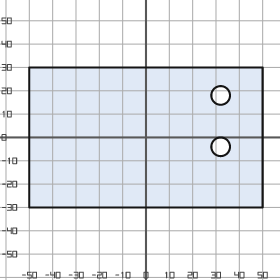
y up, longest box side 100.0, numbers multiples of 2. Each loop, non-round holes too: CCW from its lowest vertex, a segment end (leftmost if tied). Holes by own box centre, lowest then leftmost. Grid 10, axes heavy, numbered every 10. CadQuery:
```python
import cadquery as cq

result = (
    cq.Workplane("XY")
    .moveTo(-50.0, -30.0)
    .lineTo(50.0, -30.0)
    .lineTo(50.0, 30.0)
    .lineTo(-50.0, 30.0)
    .close()
    .moveTo(32.0, -4.0)
    .circle(4.0)
    .moveTo(32.0, 18.0)
    .circle(4.0)
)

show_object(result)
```